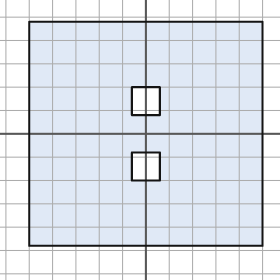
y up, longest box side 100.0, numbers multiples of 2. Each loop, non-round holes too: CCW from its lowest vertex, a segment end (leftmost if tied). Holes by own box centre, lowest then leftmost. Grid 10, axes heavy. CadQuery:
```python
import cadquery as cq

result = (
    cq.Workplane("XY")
    .moveTo(-50.0, -48.0)
    .lineTo(50.0, -48.0)
    .lineTo(50.0, 48.0)
    .lineTo(-50.0, 48.0)
    .close()
    .moveTo(-6.0, -20.0)
    .lineTo(6.0, -20.0)
    .lineTo(6.0, -8.0)
    .lineTo(-6.0, -8.0)
    .close()
    .moveTo(-6.0, 8.0)
    .lineTo(6.0, 8.0)
    .lineTo(6.0, 20.0)
    .lineTo(-6.0, 20.0)
    .close()
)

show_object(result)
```